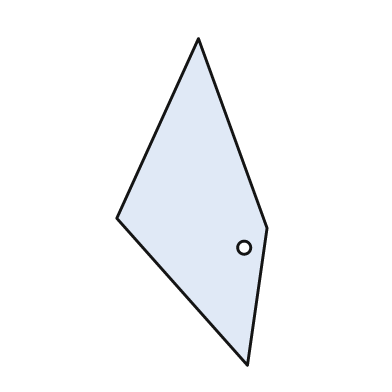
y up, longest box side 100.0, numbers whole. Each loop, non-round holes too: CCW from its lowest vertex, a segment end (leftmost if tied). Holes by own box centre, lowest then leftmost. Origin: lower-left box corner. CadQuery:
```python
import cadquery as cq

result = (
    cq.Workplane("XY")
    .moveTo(40.0, 0.0)
    .lineTo(46.0, 42.0)
    .lineTo(25.0, 100.0)
    .lineTo(0.0, 45.0)
    .close()
    .moveTo(39.0, 36.0)
    .circle(2.0)
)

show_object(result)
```